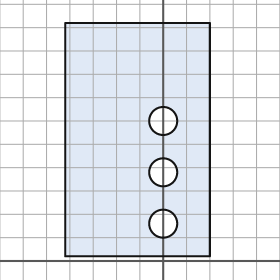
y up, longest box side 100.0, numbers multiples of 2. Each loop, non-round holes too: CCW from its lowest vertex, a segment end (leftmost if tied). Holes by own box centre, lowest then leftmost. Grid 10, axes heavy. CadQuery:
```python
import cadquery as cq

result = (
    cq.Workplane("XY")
    .moveTo(-42.0, 2.0)
    .lineTo(20.0, 2.0)
    .lineTo(20.0, 102.0)
    .lineTo(-42.0, 102.0)
    .close()
    .moveTo(0.0, 16.0)
    .circle(6.0)
    .moveTo(0.0, 38.0)
    .circle(6.0)
    .moveTo(0.0, 60.0)
    .circle(6.0)
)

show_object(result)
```